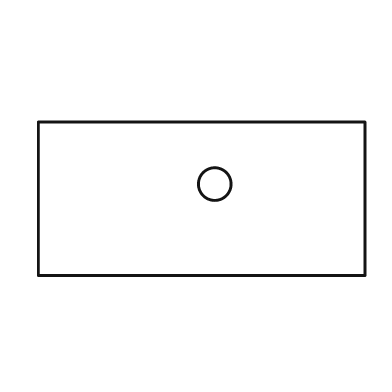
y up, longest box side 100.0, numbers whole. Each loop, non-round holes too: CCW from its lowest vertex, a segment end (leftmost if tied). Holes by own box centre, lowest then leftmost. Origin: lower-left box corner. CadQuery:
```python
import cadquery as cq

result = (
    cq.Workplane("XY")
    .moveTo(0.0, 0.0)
    .lineTo(100.0, 0.0)
    .lineTo(100.0, 47.0)
    .lineTo(0.0, 47.0)
    .close()
    .moveTo(54.0, 28.0)
    .circle(5.0)
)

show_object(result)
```